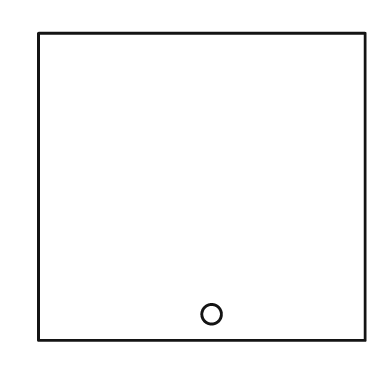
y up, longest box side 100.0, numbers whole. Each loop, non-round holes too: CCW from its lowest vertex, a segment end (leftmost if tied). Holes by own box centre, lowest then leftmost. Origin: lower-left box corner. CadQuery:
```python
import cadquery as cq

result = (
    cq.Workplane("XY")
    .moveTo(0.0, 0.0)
    .lineTo(100.0, 0.0)
    .lineTo(100.0, 94.0)
    .lineTo(0.0, 94.0)
    .close()
    .moveTo(53.0, 8.0)
    .circle(3.0)
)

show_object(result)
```